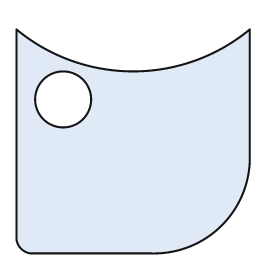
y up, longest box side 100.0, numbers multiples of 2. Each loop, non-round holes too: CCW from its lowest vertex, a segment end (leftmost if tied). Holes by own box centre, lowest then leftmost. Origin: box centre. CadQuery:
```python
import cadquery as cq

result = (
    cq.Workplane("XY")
    .moveTo(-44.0, -48.0)
    .lineTo(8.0, -48.0)
    .threePointArc((38.0, -36.0), (50.0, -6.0))
    .lineTo(50.0, 48.0)
    .threePointArc((0.0, 30.0), (-50.0, 48.0))
    .lineTo(-50.0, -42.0)
    .threePointArc((-48.0, -46.0), (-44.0, -48.0))
    .close()
    .moveTo(-30.0, 18.0)
    .circle(12.0)
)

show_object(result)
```